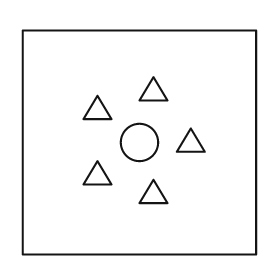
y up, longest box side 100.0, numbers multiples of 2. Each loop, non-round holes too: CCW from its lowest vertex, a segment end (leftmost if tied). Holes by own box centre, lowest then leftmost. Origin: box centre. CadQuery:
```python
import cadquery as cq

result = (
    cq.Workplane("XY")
    .moveTo(-50.0, -48.0)
    .lineTo(50.0, -48.0)
    .lineTo(50.0, 48.0)
    .lineTo(-50.0, 48.0)
    .close()
    .moveTo(0.0, -26.0)
    .lineTo(12.0, -26.0)
    .lineTo(6.0, -16.0)
    .close()
    .moveTo(-24.0, -18.0)
    .lineTo(-12.0, -18.0)
    .lineTo(-18.0, -8.0)
    .close()
    .moveTo(0.0, 0.0)
    .circle(8.0)
    .moveTo(16.0, -4.0)
    .lineTo(28.0, -4.0)
    .lineTo(22.0, 6.0)
    .close()
    .moveTo(-24.0, 10.0)
    .lineTo(-12.0, 10.0)
    .lineTo(-18.0, 20.0)
    .close()
    .moveTo(0.0, 18.0)
    .lineTo(12.0, 18.0)
    .lineTo(6.0, 28.0)
    .close()
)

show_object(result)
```